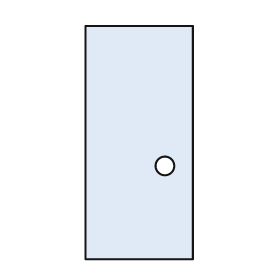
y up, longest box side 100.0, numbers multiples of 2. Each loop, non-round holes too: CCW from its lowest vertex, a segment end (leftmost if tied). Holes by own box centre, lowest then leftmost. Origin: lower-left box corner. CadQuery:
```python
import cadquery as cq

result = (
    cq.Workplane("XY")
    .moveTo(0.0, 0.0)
    .lineTo(46.0, 0.0)
    .lineTo(46.0, 100.0)
    .lineTo(0.0, 100.0)
    .close()
    .moveTo(34.0, 40.0)
    .circle(4.0)
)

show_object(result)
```